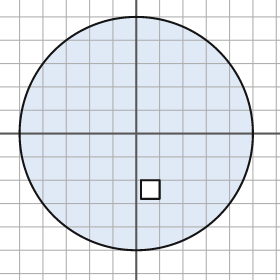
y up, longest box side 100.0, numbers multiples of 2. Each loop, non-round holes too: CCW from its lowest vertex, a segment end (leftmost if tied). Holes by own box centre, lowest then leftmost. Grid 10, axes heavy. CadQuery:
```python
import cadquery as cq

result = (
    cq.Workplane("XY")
    .moveTo(0.0, 0.0)
    .circle(50.0)
    .moveTo(2.0, -28.0)
    .lineTo(10.0, -28.0)
    .lineTo(10.0, -20.0)
    .lineTo(2.0, -20.0)
    .close()
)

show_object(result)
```